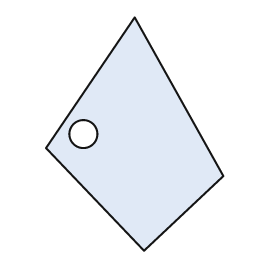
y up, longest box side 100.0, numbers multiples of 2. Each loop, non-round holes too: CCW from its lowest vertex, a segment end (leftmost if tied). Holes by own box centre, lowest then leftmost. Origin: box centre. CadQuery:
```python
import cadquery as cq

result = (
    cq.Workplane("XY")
    .moveTo(4.0, -50.0)
    .lineTo(38.0, -18.0)
    .lineTo(0.0, 50.0)
    .lineTo(-38.0, -6.0)
    .close()
    .moveTo(-22.0, 0.0)
    .circle(6.0)
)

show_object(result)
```